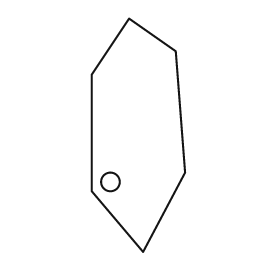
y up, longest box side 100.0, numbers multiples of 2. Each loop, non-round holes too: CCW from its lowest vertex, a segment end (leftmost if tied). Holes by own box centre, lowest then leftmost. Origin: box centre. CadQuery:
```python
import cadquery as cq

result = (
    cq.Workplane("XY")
    .moveTo(2.0, -50.0)
    .lineTo(20.0, -16.0)
    .lineTo(16.0, 36.0)
    .lineTo(-4.0, 50.0)
    .lineTo(-20.0, 26.0)
    .lineTo(-20.0, -24.0)
    .close()
    .moveTo(-12.0, -20.0)
    .circle(4.0)
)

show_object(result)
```